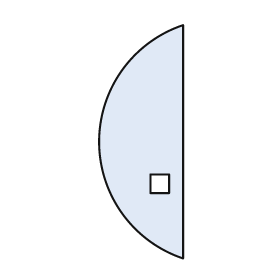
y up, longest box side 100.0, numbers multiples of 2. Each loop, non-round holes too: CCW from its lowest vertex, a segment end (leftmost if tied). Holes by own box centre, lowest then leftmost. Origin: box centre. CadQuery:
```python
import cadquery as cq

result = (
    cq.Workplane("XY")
    .moveTo(18.0, -50.0)
    .lineTo(18.0, 50.0)
    .threePointArc((-18.0, 0.0), (18.0, -50.0))
    .close()
    .moveTo(4.0, -22.0)
    .lineTo(12.0, -22.0)
    .lineTo(12.0, -14.0)
    .lineTo(4.0, -14.0)
    .close()
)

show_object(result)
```